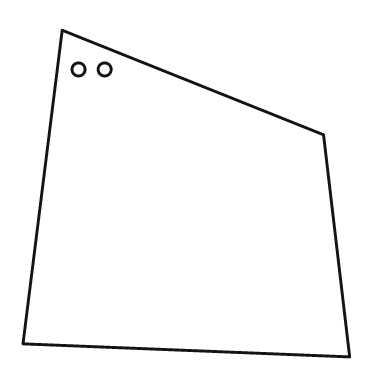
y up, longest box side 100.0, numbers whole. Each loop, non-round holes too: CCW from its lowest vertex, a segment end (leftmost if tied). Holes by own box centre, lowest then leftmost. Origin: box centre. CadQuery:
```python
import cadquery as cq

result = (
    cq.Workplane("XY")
    .moveTo(50.0, -50.0)
    .lineTo(42.0, 18.0)
    .lineTo(-38.0, 50.0)
    .lineTo(-50.0, -46.0)
    .close()
    .moveTo(-33.0, 38.0)
    .circle(2.0)
    .moveTo(-25.0, 38.0)
    .circle(2.0)
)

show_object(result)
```